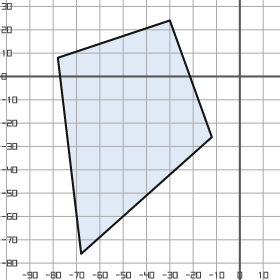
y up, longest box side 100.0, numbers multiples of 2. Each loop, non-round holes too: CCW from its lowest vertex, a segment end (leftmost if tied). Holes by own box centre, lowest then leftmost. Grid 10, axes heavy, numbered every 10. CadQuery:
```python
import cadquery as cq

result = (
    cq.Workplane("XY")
    .moveTo(-68.0, -76.0)
    .lineTo(-12.0, -26.0)
    .lineTo(-30.0, 24.0)
    .lineTo(-78.0, 8.0)
    .close()
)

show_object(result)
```